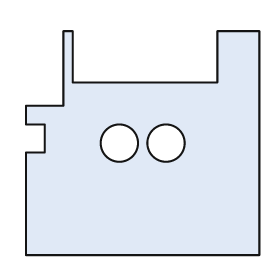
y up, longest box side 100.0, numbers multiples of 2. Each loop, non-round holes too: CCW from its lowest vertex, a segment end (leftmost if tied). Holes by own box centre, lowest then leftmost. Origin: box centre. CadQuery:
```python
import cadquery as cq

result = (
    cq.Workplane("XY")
    .moveTo(-50.0, -48.0)
    .lineTo(50.0, -48.0)
    .lineTo(50.0, 48.0)
    .lineTo(32.0, 48.0)
    .lineTo(32.0, 26.0)
    .lineTo(-30.0, 26.0)
    .lineTo(-30.0, 48.0)
    .lineTo(-34.0, 48.0)
    .lineTo(-34.0, 16.0)
    .lineTo(-50.0, 16.0)
    .lineTo(-50.0, 8.0)
    .lineTo(-42.0, 8.0)
    .lineTo(-42.0, -4.0)
    .lineTo(-50.0, -4.0)
    .close()
    .moveTo(-10.0, 0.0)
    .circle(8.0)
    .moveTo(10.0, 0.0)
    .circle(8.0)
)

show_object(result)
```